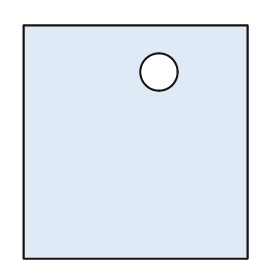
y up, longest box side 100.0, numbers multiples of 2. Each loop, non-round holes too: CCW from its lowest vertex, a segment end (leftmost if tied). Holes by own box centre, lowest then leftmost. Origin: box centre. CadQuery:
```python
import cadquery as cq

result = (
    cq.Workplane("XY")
    .moveTo(-48.0, -50.0)
    .lineTo(48.0, -50.0)
    .lineTo(48.0, 50.0)
    .lineTo(-48.0, 50.0)
    .close()
    .moveTo(10.0, 30.0)
    .circle(8.0)
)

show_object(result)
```